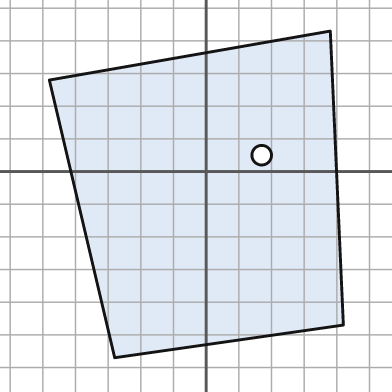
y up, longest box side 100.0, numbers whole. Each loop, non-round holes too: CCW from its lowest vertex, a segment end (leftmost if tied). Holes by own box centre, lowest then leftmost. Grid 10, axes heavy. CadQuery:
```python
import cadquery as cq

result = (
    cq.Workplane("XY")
    .moveTo(-28.0, -57.0)
    .lineTo(42.0, -47.0)
    .lineTo(38.0, 43.0)
    .lineTo(-48.0, 28.0)
    .close()
    .moveTo(17.0, 5.0)
    .circle(3.0)
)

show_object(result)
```